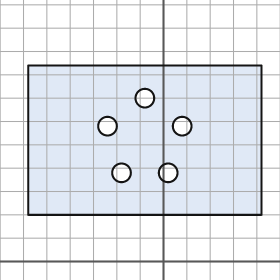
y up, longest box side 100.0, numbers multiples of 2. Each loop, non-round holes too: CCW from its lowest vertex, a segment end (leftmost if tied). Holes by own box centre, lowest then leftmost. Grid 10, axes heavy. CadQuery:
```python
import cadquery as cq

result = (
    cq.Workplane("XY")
    .moveTo(-58.0, 20.0)
    .lineTo(42.0, 20.0)
    .lineTo(42.0, 84.0)
    .lineTo(-58.0, 84.0)
    .close()
    .moveTo(-18.0, 38.0)
    .circle(4.0)
    .moveTo(2.0, 38.0)
    .circle(4.0)
    .moveTo(-24.0, 58.0)
    .circle(4.0)
    .moveTo(8.0, 58.0)
    .circle(4.0)
    .moveTo(-8.0, 70.0)
    .circle(4.0)
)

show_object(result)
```